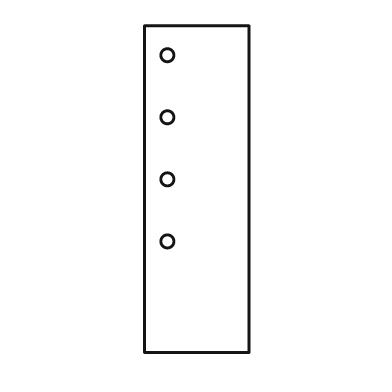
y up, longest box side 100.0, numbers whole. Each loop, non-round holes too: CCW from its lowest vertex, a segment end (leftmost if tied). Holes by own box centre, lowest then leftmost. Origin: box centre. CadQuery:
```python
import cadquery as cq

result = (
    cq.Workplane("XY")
    .moveTo(-16.0, -50.0)
    .lineTo(16.0, -50.0)
    .lineTo(16.0, 50.0)
    .lineTo(-16.0, 50.0)
    .close()
    .moveTo(-9.0, -16.0)
    .circle(2.0)
    .moveTo(-9.0, 3.0)
    .circle(2.0)
    .moveTo(-9.0, 22.0)
    .circle(2.0)
    .moveTo(-9.0, 41.0)
    .circle(2.0)
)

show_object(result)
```